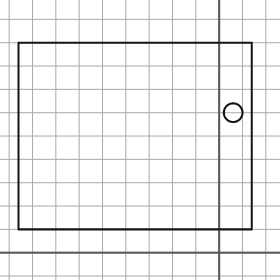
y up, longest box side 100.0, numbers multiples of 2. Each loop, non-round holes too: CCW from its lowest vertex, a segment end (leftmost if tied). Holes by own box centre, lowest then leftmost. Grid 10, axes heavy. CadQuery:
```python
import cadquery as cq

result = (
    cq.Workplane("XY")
    .moveTo(-86.0, 10.0)
    .lineTo(14.0, 10.0)
    .lineTo(14.0, 90.0)
    .lineTo(-86.0, 90.0)
    .close()
    .moveTo(6.0, 60.0)
    .circle(4.0)
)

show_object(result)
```